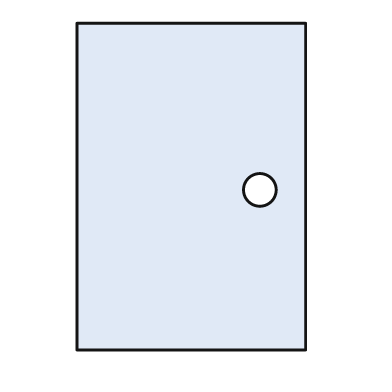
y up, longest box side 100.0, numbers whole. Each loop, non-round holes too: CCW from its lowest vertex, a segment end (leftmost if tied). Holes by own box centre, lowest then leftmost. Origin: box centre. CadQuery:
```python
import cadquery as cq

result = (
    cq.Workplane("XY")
    .moveTo(-35.0, -50.0)
    .lineTo(35.0, -50.0)
    .lineTo(35.0, 50.0)
    .lineTo(-35.0, 50.0)
    .close()
    .moveTo(21.0, -1.0)
    .circle(5.0)
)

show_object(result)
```